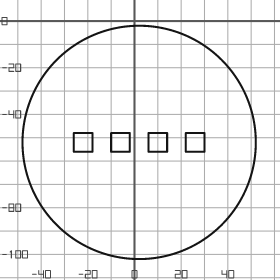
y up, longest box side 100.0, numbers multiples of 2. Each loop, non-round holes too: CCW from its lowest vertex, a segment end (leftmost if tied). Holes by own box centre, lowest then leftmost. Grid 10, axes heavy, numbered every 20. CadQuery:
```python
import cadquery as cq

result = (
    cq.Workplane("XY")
    .moveTo(2.0, -52.0)
    .circle(50.0)
    .moveTo(-26.0, -56.0)
    .lineTo(-18.0, -56.0)
    .lineTo(-18.0, -48.0)
    .lineTo(-26.0, -48.0)
    .close()
    .moveTo(-10.0, -56.0)
    .lineTo(-2.0, -56.0)
    .lineTo(-2.0, -48.0)
    .lineTo(-10.0, -48.0)
    .close()
    .moveTo(6.0, -56.0)
    .lineTo(14.0, -56.0)
    .lineTo(14.0, -48.0)
    .lineTo(6.0, -48.0)
    .close()
    .moveTo(22.0, -56.0)
    .lineTo(30.0, -56.0)
    .lineTo(30.0, -48.0)
    .lineTo(22.0, -48.0)
    .close()
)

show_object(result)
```